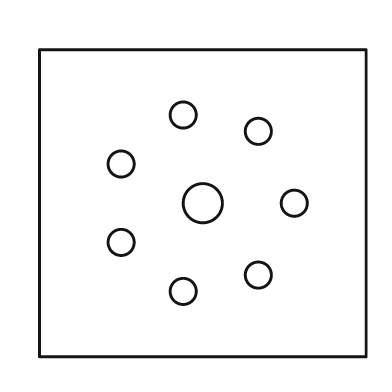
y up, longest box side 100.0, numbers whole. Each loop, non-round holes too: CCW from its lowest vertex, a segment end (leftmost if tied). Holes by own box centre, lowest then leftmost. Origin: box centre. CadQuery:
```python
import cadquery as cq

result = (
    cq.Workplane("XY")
    .moveTo(-50.0, -47.0)
    .lineTo(50.0, -47.0)
    .lineTo(50.0, 47.0)
    .lineTo(-50.0, 47.0)
    .close()
    .moveTo(-6.0, -27.0)
    .circle(4.0)
    .moveTo(17.0, -22.0)
    .circle(4.0)
    .moveTo(-25.0, -12.0)
    .circle(4.0)
    .moveTo(0.0, 0.0)
    .circle(6.0)
    .moveTo(28.0, 0.0)
    .circle(4.0)
    .moveTo(-25.0, 12.0)
    .circle(4.0)
    .moveTo(17.0, 22.0)
    .circle(4.0)
    .moveTo(-6.0, 27.0)
    .circle(4.0)
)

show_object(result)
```